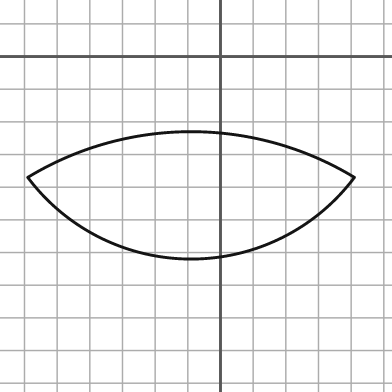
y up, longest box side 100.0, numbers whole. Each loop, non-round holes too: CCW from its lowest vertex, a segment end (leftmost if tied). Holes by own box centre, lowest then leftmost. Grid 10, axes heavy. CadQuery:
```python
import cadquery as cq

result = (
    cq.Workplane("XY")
    .moveTo(-59.0, -37.0)
    .threePointArc((-9.0, -62.0), (41.0, -37.0))
    .threePointArc((-9.0, -23.0), (-59.0, -37.0))
    .close()
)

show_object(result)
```